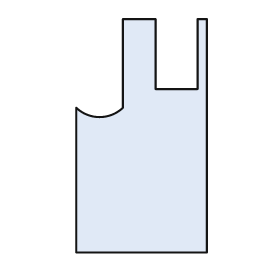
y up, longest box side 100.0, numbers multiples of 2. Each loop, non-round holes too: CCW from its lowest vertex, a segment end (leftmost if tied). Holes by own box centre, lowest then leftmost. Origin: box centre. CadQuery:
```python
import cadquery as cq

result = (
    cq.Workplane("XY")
    .moveTo(-28.0, -50.0)
    .lineTo(28.0, -50.0)
    .lineTo(28.0, 50.0)
    .lineTo(24.0, 50.0)
    .lineTo(24.0, 20.0)
    .lineTo(6.0, 20.0)
    .lineTo(6.0, 50.0)
    .lineTo(-8.0, 50.0)
    .lineTo(-8.0, 12.0)
    .threePointArc((-18.0, 8.0), (-28.0, 12.0))
    .close()
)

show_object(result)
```